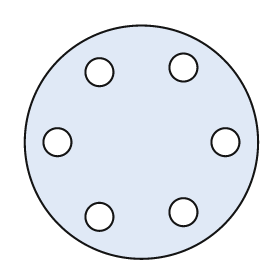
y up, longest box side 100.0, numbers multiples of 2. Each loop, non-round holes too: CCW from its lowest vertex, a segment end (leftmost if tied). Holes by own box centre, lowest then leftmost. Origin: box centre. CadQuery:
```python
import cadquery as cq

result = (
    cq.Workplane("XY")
    .moveTo(0.0, 0.0)
    .circle(50.0)
    .moveTo(-18.0, -32.0)
    .circle(6.0)
    .moveTo(18.0, -30.0)
    .circle(6.0)
    .moveTo(-36.0, 0.0)
    .circle(6.0)
    .moveTo(36.0, 0.0)
    .circle(6.0)
    .moveTo(-18.0, 30.0)
    .circle(6.0)
    .moveTo(18.0, 32.0)
    .circle(6.0)
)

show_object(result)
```